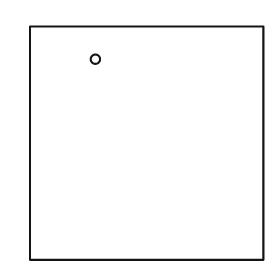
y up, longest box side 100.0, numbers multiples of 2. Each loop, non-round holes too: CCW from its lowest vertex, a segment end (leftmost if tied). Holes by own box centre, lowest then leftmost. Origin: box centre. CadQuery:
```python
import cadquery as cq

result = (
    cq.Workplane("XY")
    .moveTo(-50.0, -50.0)
    .lineTo(50.0, -50.0)
    .lineTo(50.0, 50.0)
    .lineTo(-50.0, 50.0)
    .close()
    .moveTo(-22.0, 36.0)
    .circle(2.0)
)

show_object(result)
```